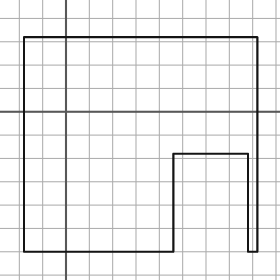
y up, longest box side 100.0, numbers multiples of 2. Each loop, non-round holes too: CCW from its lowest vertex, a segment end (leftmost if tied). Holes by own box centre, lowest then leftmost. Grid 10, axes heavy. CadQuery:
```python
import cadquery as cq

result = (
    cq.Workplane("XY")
    .moveTo(-18.0, -60.0)
    .lineTo(46.0, -60.0)
    .lineTo(46.0, -18.0)
    .lineTo(78.0, -18.0)
    .lineTo(78.0, -60.0)
    .lineTo(82.0, -60.0)
    .lineTo(82.0, 32.0)
    .lineTo(-18.0, 32.0)
    .close()
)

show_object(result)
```